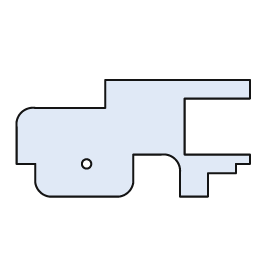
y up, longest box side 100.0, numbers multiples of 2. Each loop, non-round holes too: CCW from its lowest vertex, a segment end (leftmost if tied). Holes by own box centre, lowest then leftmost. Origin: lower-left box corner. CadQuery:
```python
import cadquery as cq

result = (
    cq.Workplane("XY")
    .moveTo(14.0, 0.0)
    .lineTo(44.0, 0.0)
    .threePointArc((48.0, 2.0), (50.0, 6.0))
    .lineTo(50.0, 18.0)
    .lineTo(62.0, 18.0)
    .threePointArc((68.0, 16.0), (70.0, 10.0))
    .lineTo(70.0, 0.0)
    .lineTo(82.0, 0.0)
    .lineTo(82.0, 10.0)
    .lineTo(94.0, 10.0)
    .lineTo(94.0, 14.0)
    .lineTo(100.0, 14.0)
    .lineTo(100.0, 18.0)
    .lineTo(72.0, 18.0)
    .lineTo(72.0, 42.0)
    .lineTo(100.0, 42.0)
    .lineTo(100.0, 50.0)
    .lineTo(38.0, 50.0)
    .lineTo(38.0, 38.0)
    .lineTo(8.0, 38.0)
    .threePointArc((2.0, 36.0), (0.0, 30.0))
    .lineTo(0.0, 14.0)
    .lineTo(8.0, 14.0)
    .lineTo(8.0, 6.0)
    .threePointArc((10.0, 2.0), (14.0, 0.0))
    .close()
    .moveTo(30.0, 14.0)
    .circle(2.0)
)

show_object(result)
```